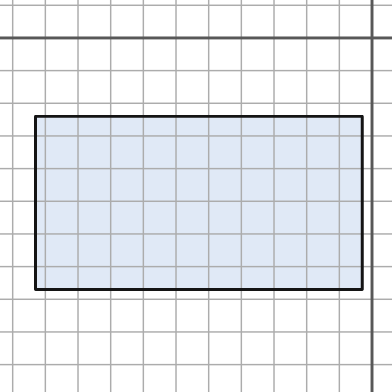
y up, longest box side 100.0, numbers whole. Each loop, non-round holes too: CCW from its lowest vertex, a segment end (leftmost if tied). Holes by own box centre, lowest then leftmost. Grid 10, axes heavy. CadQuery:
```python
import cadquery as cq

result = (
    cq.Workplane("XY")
    .moveTo(-103.0, -77.0)
    .lineTo(-3.0, -77.0)
    .lineTo(-3.0, -24.0)
    .lineTo(-103.0, -24.0)
    .close()
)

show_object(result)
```